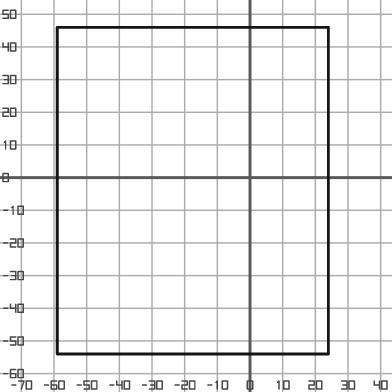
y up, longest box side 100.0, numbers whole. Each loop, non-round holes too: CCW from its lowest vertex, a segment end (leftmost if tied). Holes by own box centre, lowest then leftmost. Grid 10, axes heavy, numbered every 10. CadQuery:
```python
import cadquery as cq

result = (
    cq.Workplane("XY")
    .moveTo(-59.0, -54.0)
    .lineTo(24.0, -54.0)
    .lineTo(24.0, 46.0)
    .lineTo(-59.0, 46.0)
    .close()
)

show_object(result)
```